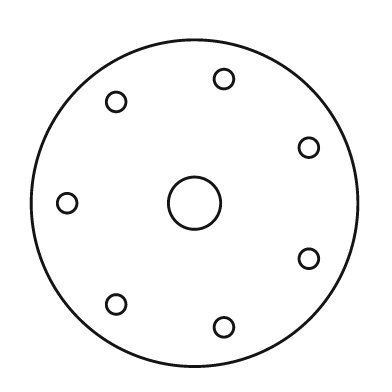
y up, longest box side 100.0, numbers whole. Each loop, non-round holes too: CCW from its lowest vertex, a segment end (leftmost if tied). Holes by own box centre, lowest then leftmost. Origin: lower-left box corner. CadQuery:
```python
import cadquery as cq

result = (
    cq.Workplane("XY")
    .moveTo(50.0, 50.0)
    .circle(50.0)
    .moveTo(59.0, 12.0)
    .circle(3.0)
    .moveTo(26.0, 19.0)
    .circle(3.0)
    .moveTo(85.0, 33.0)
    .circle(3.0)
    .moveTo(11.0, 50.0)
    .circle(3.0)
    .moveTo(50.0, 50.0)
    .circle(8.0)
    .moveTo(85.0, 67.0)
    .circle(3.0)
    .moveTo(26.0, 81.0)
    .circle(3.0)
    .moveTo(59.0, 88.0)
    .circle(3.0)
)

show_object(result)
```